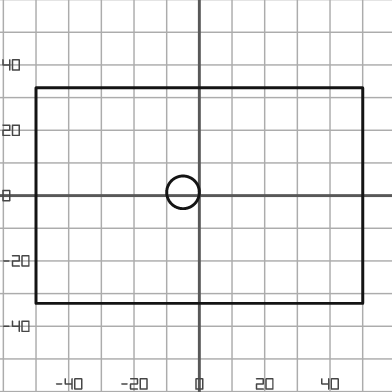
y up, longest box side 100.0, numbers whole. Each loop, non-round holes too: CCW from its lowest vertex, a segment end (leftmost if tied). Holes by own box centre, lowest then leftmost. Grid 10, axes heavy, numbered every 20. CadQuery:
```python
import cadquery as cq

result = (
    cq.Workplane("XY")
    .moveTo(-50.0, -33.0)
    .lineTo(50.0, -33.0)
    .lineTo(50.0, 33.0)
    .lineTo(-50.0, 33.0)
    .close()
    .moveTo(-5.0, 1.0)
    .circle(5.0)
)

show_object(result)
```